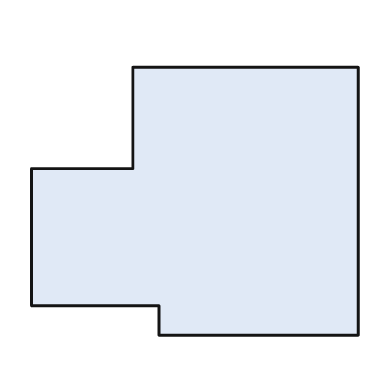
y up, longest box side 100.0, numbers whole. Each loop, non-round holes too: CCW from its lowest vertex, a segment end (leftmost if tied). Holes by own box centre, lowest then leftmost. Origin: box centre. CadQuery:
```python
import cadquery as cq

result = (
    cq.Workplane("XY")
    .moveTo(-11.0, -41.0)
    .lineTo(50.0, -41.0)
    .lineTo(50.0, 41.0)
    .lineTo(-19.0, 41.0)
    .lineTo(-19.0, 10.0)
    .lineTo(-50.0, 10.0)
    .lineTo(-50.0, -32.0)
    .lineTo(-11.0, -32.0)
    .close()
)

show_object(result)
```